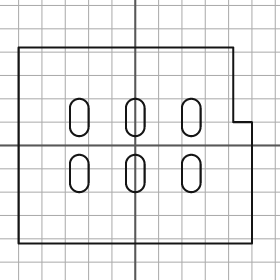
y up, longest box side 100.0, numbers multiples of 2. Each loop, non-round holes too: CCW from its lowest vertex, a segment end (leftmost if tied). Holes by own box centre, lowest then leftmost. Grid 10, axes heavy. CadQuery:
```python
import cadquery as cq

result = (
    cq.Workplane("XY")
    .moveTo(-50.0, -42.0)
    .lineTo(50.0, -42.0)
    .lineTo(50.0, 10.0)
    .lineTo(42.0, 10.0)
    .lineTo(42.0, 42.0)
    .lineTo(-50.0, 42.0)
    .close()
    .moveTo(-28.0, -16.0)
    .threePointArc((-24.0, -20.0), (-20.0, -16.0))
    .lineTo(-20.0, -8.0)
    .threePointArc((-24.0, -4.0), (-28.0, -8.0))
    .close()
    .moveTo(-4.0, -16.0)
    .threePointArc((0.0, -20.0), (4.0, -16.0))
    .lineTo(4.0, -8.0)
    .threePointArc((0.0, -4.0), (-4.0, -8.0))
    .close()
    .moveTo(20.0, -16.0)
    .threePointArc((24.0, -20.0), (28.0, -16.0))
    .lineTo(28.0, -8.0)
    .threePointArc((24.0, -4.0), (20.0, -8.0))
    .close()
    .moveTo(-28.0, 8.0)
    .threePointArc((-24.0, 4.0), (-20.0, 8.0))
    .lineTo(-20.0, 16.0)
    .threePointArc((-24.0, 20.0), (-28.0, 16.0))
    .close()
    .moveTo(-4.0, 8.0)
    .threePointArc((0.0, 4.0), (4.0, 8.0))
    .lineTo(4.0, 16.0)
    .threePointArc((0.0, 20.0), (-4.0, 16.0))
    .close()
    .moveTo(20.0, 8.0)
    .threePointArc((24.0, 4.0), (28.0, 8.0))
    .lineTo(28.0, 16.0)
    .threePointArc((24.0, 20.0), (20.0, 16.0))
    .close()
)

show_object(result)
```